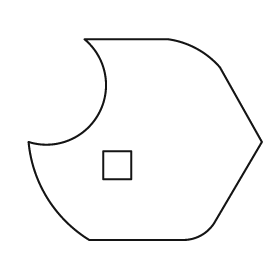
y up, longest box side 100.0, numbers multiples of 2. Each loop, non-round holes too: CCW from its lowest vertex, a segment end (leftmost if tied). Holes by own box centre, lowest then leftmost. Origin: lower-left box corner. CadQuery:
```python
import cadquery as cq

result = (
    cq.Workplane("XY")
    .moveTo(26.0, 0.0)
    .lineTo(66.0, 0.0)
    .threePointArc((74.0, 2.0), (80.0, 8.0))
    .lineTo(100.0, 42.0)
    .lineTo(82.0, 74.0)
    .threePointArc((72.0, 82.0), (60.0, 86.0))
    .lineTo(24.0, 86.0)
    .threePointArc((30.0, 54.0), (0.0, 42.0))
    .threePointArc((8.0, 18.0), (26.0, 0.0))
    .close()
    .moveTo(32.0, 26.0)
    .lineTo(44.0, 26.0)
    .lineTo(44.0, 38.0)
    .lineTo(32.0, 38.0)
    .close()
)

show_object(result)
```